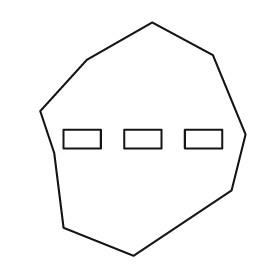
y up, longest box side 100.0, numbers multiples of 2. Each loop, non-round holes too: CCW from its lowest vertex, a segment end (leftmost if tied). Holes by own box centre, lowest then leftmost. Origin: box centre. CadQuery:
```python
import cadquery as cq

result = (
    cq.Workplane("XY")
    .moveTo(-4.0, -50.0)
    .lineTo(38.0, -22.0)
    .lineTo(44.0, 2.0)
    .lineTo(30.0, 36.0)
    .lineTo(4.0, 50.0)
    .lineTo(-24.0, 34.0)
    .lineTo(-44.0, 12.0)
    .lineTo(-38.0, -6.0)
    .lineTo(-34.0, -38.0)
    .close()
    .moveTo(-34.0, -4.0)
    .lineTo(-18.0, -4.0)
    .lineTo(-18.0, 4.0)
    .lineTo(-34.0, 4.0)
    .close()
    .moveTo(-8.0, -4.0)
    .lineTo(8.0, -4.0)
    .lineTo(8.0, 4.0)
    .lineTo(-8.0, 4.0)
    .close()
    .moveTo(18.0, -4.0)
    .lineTo(34.0, -4.0)
    .lineTo(34.0, 4.0)
    .lineTo(18.0, 4.0)
    .close()
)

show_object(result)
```